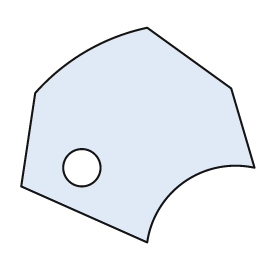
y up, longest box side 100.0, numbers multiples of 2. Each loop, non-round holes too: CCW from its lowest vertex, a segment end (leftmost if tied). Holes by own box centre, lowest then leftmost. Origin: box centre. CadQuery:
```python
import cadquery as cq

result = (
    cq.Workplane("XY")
    .moveTo(4.0, -46.0)
    .threePointArc((20.0, -20.0), (50.0, -14.0))
    .lineTo(40.0, 20.0)
    .lineTo(4.0, 46.0)
    .threePointArc((-22.0, 36.0), (-44.0, 18.0))
    .lineTo(-50.0, -22.0)
    .close()
    .moveTo(-24.0, -14.0)
    .circle(8.0)
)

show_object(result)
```